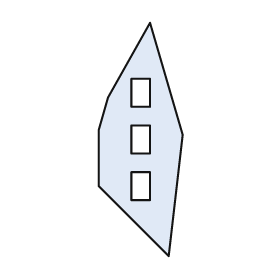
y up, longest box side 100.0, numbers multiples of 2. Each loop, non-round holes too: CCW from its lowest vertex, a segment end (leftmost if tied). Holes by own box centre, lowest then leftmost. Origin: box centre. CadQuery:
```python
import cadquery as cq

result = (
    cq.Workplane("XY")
    .moveTo(12.0, -50.0)
    .lineTo(18.0, 2.0)
    .lineTo(4.0, 50.0)
    .lineTo(-14.0, 18.0)
    .lineTo(-18.0, 4.0)
    .lineTo(-18.0, -20.0)
    .close()
    .moveTo(-4.0, -26.0)
    .lineTo(4.0, -26.0)
    .lineTo(4.0, -14.0)
    .lineTo(-4.0, -14.0)
    .close()
    .moveTo(-4.0, -6.0)
    .lineTo(4.0, -6.0)
    .lineTo(4.0, 6.0)
    .lineTo(-4.0, 6.0)
    .close()
    .moveTo(-4.0, 14.0)
    .lineTo(4.0, 14.0)
    .lineTo(4.0, 26.0)
    .lineTo(-4.0, 26.0)
    .close()
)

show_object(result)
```